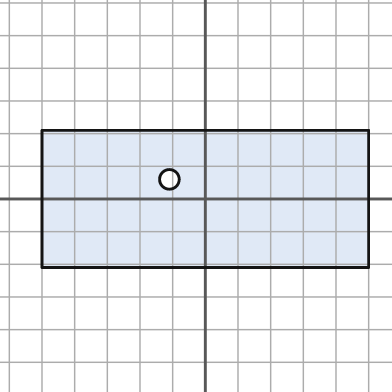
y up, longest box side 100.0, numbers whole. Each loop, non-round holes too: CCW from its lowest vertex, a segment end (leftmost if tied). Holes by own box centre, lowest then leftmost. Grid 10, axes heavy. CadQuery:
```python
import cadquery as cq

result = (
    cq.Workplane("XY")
    .moveTo(-50.0, -21.0)
    .lineTo(50.0, -21.0)
    .lineTo(50.0, 21.0)
    .lineTo(-50.0, 21.0)
    .close()
    .moveTo(-11.0, 6.0)
    .circle(3.0)
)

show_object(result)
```